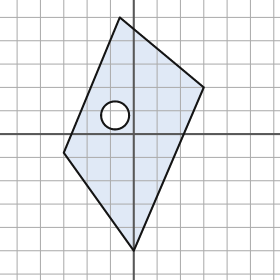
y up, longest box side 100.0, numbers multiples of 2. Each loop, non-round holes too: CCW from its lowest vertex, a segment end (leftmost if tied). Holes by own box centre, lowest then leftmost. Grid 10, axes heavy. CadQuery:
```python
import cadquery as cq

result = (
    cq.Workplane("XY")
    .moveTo(0.0, -50.0)
    .lineTo(30.0, 20.0)
    .lineTo(-6.0, 50.0)
    .lineTo(-30.0, -8.0)
    .close()
    .moveTo(-8.0, 8.0)
    .circle(6.0)
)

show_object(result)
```